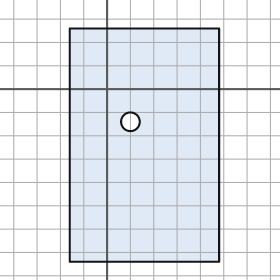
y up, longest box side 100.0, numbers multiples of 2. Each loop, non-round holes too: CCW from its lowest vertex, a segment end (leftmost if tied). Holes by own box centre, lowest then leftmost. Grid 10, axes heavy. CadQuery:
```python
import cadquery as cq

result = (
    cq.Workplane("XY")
    .moveTo(-16.0, -74.0)
    .lineTo(48.0, -74.0)
    .lineTo(48.0, 26.0)
    .lineTo(-16.0, 26.0)
    .close()
    .moveTo(10.0, -14.0)
    .circle(4.0)
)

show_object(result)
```